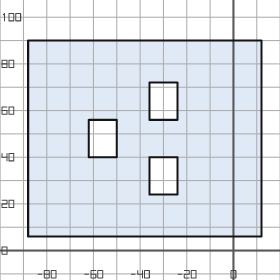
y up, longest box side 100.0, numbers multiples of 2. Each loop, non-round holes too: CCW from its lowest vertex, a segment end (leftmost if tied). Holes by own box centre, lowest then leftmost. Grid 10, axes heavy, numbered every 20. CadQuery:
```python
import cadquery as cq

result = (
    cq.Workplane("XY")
    .moveTo(-88.0, 6.0)
    .lineTo(12.0, 6.0)
    .lineTo(12.0, 90.0)
    .lineTo(-88.0, 90.0)
    .close()
    .moveTo(-36.0, 24.0)
    .lineTo(-24.0, 24.0)
    .lineTo(-24.0, 40.0)
    .lineTo(-36.0, 40.0)
    .close()
    .moveTo(-62.0, 40.0)
    .lineTo(-50.0, 40.0)
    .lineTo(-50.0, 56.0)
    .lineTo(-62.0, 56.0)
    .close()
    .moveTo(-36.0, 56.0)
    .lineTo(-24.0, 56.0)
    .lineTo(-24.0, 72.0)
    .lineTo(-36.0, 72.0)
    .close()
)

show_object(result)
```